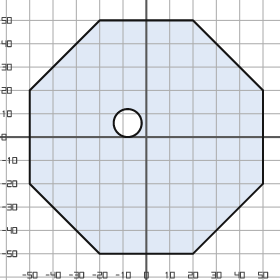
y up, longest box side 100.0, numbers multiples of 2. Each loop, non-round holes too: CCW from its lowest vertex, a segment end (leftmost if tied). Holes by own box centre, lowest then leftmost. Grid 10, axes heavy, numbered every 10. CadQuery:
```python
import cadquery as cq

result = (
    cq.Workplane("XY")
    .moveTo(-20.0, -50.0)
    .lineTo(20.0, -50.0)
    .lineTo(50.0, -20.0)
    .lineTo(50.0, 20.0)
    .lineTo(20.0, 50.0)
    .lineTo(-20.0, 50.0)
    .lineTo(-50.0, 20.0)
    .lineTo(-50.0, -20.0)
    .close()
    .moveTo(-8.0, 6.0)
    .circle(6.0)
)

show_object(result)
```